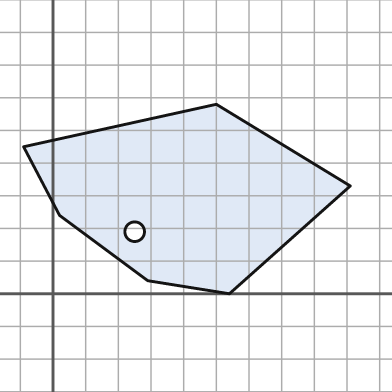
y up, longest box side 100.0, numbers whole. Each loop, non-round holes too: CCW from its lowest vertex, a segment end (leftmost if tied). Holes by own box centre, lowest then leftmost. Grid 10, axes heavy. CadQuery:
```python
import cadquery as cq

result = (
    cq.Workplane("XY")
    .moveTo(54.0, 0.0)
    .lineTo(91.0, 33.0)
    .lineTo(50.0, 58.0)
    .lineTo(-9.0, 45.0)
    .lineTo(2.0, 24.0)
    .lineTo(29.0, 4.0)
    .close()
    .moveTo(25.0, 19.0)
    .circle(3.0)
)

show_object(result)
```